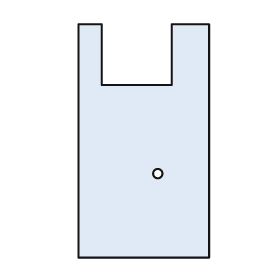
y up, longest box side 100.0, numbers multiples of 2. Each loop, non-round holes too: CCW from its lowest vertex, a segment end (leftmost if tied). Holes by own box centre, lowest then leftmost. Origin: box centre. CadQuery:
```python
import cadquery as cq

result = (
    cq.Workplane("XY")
    .moveTo(-28.0, -50.0)
    .lineTo(28.0, -50.0)
    .lineTo(28.0, 50.0)
    .lineTo(12.0, 50.0)
    .lineTo(12.0, 24.0)
    .lineTo(-18.0, 24.0)
    .lineTo(-18.0, 50.0)
    .lineTo(-28.0, 50.0)
    .close()
    .moveTo(6.0, -14.0)
    .circle(2.0)
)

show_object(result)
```